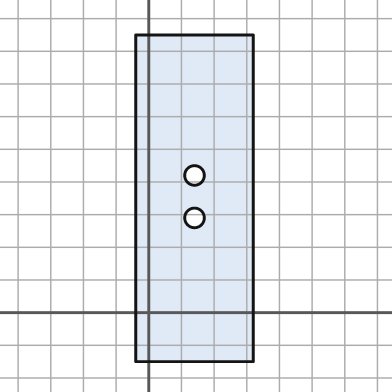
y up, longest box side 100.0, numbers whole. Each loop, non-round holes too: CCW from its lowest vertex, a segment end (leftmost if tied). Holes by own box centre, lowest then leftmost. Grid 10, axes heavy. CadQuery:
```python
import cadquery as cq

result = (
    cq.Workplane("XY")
    .moveTo(-4.0, -15.0)
    .lineTo(32.0, -15.0)
    .lineTo(32.0, 85.0)
    .lineTo(-4.0, 85.0)
    .close()
    .moveTo(14.0, 29.0)
    .circle(3.0)
    .moveTo(14.0, 42.0)
    .circle(3.0)
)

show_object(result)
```